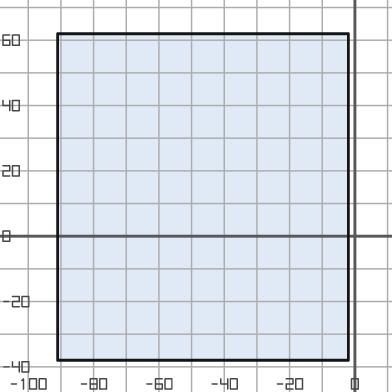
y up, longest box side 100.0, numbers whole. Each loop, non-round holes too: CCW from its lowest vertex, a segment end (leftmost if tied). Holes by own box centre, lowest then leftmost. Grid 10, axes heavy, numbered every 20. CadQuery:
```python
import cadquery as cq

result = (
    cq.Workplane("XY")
    .moveTo(-91.0, -38.0)
    .lineTo(-2.0, -38.0)
    .lineTo(-2.0, 62.0)
    .lineTo(-91.0, 62.0)
    .close()
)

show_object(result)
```